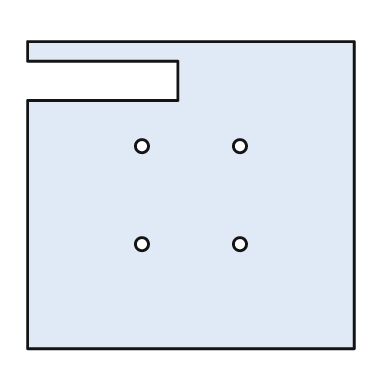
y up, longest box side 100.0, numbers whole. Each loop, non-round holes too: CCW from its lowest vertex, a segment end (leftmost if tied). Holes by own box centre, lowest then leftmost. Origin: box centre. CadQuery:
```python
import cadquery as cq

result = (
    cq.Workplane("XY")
    .moveTo(-50.0, -47.0)
    .lineTo(50.0, -47.0)
    .lineTo(50.0, 47.0)
    .lineTo(-50.0, 47.0)
    .lineTo(-50.0, 41.0)
    .lineTo(-4.0, 41.0)
    .lineTo(-4.0, 29.0)
    .lineTo(-50.0, 29.0)
    .close()
    .moveTo(-15.0, -15.0)
    .circle(2.0)
    .moveTo(15.0, -15.0)
    .circle(2.0)
    .moveTo(-15.0, 15.0)
    .circle(2.0)
    .moveTo(15.0, 15.0)
    .circle(2.0)
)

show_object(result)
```